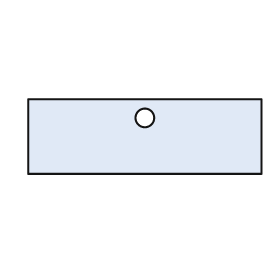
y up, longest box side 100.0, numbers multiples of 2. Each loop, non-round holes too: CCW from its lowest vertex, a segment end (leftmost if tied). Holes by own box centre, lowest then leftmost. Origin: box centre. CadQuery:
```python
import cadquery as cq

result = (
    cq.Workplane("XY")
    .moveTo(-50.0, -16.0)
    .lineTo(50.0, -16.0)
    .lineTo(50.0, 16.0)
    .lineTo(-50.0, 16.0)
    .close()
    .moveTo(0.0, 8.0)
    .circle(4.0)
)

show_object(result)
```